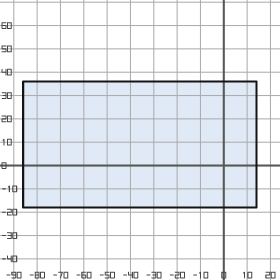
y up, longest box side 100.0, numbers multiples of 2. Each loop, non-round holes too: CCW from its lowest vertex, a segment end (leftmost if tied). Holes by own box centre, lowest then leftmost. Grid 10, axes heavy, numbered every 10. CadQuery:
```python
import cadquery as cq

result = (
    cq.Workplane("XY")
    .moveTo(-86.0, -18.0)
    .lineTo(14.0, -18.0)
    .lineTo(14.0, 36.0)
    .lineTo(-86.0, 36.0)
    .close()
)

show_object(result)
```